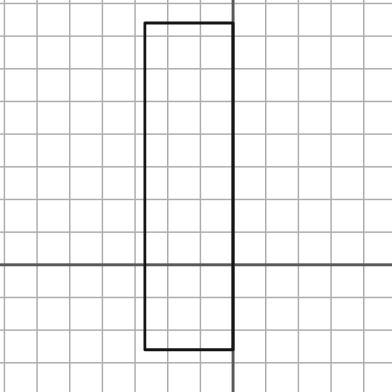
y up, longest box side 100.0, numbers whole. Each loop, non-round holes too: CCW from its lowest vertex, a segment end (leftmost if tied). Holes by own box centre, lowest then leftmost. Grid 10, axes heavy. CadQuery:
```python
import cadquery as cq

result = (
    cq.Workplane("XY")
    .moveTo(-27.0, -26.0)
    .lineTo(0.0, -26.0)
    .lineTo(0.0, 74.0)
    .lineTo(-27.0, 74.0)
    .close()
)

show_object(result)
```